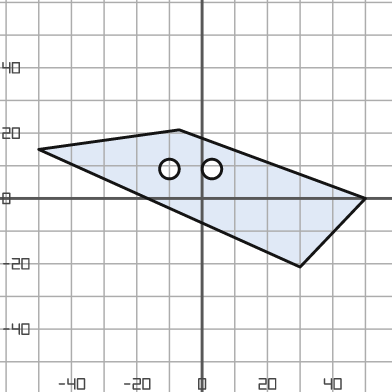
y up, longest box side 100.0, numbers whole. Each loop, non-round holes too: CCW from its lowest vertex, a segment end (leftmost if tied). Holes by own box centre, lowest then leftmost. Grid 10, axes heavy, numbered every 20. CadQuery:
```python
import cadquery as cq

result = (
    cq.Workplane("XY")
    .moveTo(30.0, -21.0)
    .lineTo(50.0, 0.0)
    .lineTo(-7.0, 21.0)
    .lineTo(-50.0, 15.0)
    .close()
    .moveTo(-10.0, 9.0)
    .circle(3.0)
    .moveTo(3.0, 9.0)
    .circle(3.0)
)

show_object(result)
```